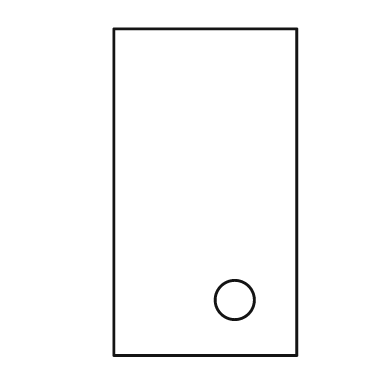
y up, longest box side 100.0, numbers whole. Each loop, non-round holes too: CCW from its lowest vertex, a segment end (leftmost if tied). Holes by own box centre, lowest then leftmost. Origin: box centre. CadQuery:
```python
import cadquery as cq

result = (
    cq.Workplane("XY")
    .moveTo(-28.0, -50.0)
    .lineTo(28.0, -50.0)
    .lineTo(28.0, 50.0)
    .lineTo(-28.0, 50.0)
    .close()
    .moveTo(9.0, -33.0)
    .circle(6.0)
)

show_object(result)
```